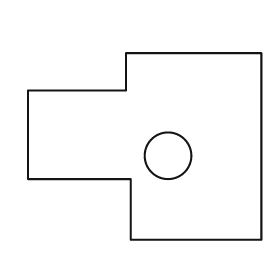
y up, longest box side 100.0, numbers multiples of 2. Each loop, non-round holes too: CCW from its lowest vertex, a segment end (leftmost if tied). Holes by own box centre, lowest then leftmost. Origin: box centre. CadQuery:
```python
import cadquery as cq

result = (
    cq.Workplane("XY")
    .moveTo(-6.0, -40.0)
    .lineTo(50.0, -40.0)
    .lineTo(50.0, 40.0)
    .lineTo(-8.0, 40.0)
    .lineTo(-8.0, 24.0)
    .lineTo(-50.0, 24.0)
    .lineTo(-50.0, -14.0)
    .lineTo(-6.0, -14.0)
    .close()
    .moveTo(10.0, -4.0)
    .circle(10.0)
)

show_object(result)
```